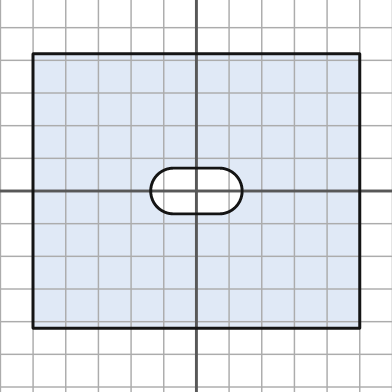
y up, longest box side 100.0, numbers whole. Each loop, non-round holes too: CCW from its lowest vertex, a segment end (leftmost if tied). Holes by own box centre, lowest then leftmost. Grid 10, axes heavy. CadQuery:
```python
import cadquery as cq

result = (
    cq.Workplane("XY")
    .moveTo(-50.0, -42.0)
    .lineTo(50.0, -42.0)
    .lineTo(50.0, 42.0)
    .lineTo(-50.0, 42.0)
    .close()
    .moveTo(-7.0, -7.0)
    .lineTo(7.0, -7.0)
    .threePointArc((14.0, 0.0), (7.0, 7.0))
    .lineTo(-7.0, 7.0)
    .threePointArc((-14.0, 0.0), (-7.0, -7.0))
    .close()
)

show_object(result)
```